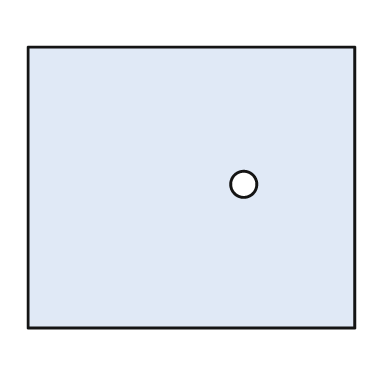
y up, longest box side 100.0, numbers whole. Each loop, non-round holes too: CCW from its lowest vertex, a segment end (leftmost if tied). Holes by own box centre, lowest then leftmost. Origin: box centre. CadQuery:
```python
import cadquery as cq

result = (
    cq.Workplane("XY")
    .moveTo(-50.0, -43.0)
    .lineTo(50.0, -43.0)
    .lineTo(50.0, 43.0)
    .lineTo(-50.0, 43.0)
    .close()
    .moveTo(16.0, 1.0)
    .circle(4.0)
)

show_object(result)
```